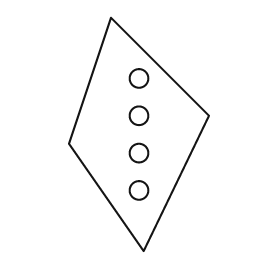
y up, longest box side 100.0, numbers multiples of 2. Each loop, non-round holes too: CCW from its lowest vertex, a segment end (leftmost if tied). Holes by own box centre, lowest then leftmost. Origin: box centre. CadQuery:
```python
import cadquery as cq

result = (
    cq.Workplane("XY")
    .moveTo(2.0, -50.0)
    .lineTo(30.0, 8.0)
    .lineTo(-12.0, 50.0)
    .lineTo(-30.0, -4.0)
    .close()
    .moveTo(0.0, -24.0)
    .circle(4.0)
    .moveTo(0.0, -8.0)
    .circle(4.0)
    .moveTo(0.0, 8.0)
    .circle(4.0)
    .moveTo(0.0, 24.0)
    .circle(4.0)
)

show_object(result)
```